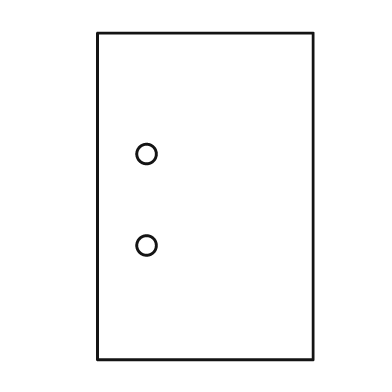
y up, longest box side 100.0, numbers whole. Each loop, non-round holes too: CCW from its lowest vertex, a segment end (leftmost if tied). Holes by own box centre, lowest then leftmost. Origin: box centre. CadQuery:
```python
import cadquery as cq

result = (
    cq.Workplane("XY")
    .moveTo(-33.0, -50.0)
    .lineTo(33.0, -50.0)
    .lineTo(33.0, 50.0)
    .lineTo(-33.0, 50.0)
    .close()
    .moveTo(-18.0, -15.0)
    .circle(3.0)
    .moveTo(-18.0, 13.0)
    .circle(3.0)
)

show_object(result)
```